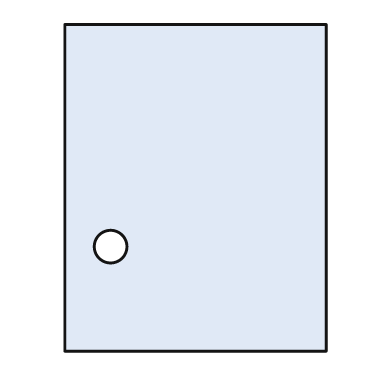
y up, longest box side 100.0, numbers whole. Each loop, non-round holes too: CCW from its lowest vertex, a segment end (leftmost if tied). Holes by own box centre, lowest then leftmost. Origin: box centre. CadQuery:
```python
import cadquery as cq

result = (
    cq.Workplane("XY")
    .moveTo(-40.0, -50.0)
    .lineTo(40.0, -50.0)
    .lineTo(40.0, 50.0)
    .lineTo(-40.0, 50.0)
    .close()
    .moveTo(-26.0, -18.0)
    .circle(5.0)
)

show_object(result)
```